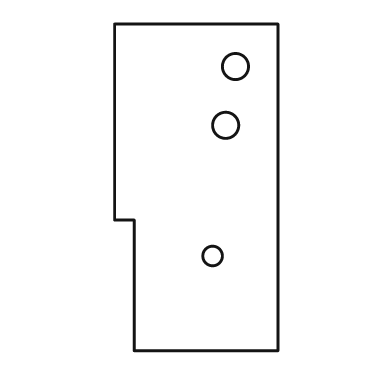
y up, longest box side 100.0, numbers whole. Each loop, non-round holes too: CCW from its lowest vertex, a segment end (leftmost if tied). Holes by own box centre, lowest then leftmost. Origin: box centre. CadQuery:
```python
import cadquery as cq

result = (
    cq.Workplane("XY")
    .moveTo(-19.0, -50.0)
    .lineTo(25.0, -50.0)
    .lineTo(25.0, 50.0)
    .lineTo(-25.0, 50.0)
    .lineTo(-25.0, -10.0)
    .lineTo(-19.0, -10.0)
    .close()
    .moveTo(5.0, -21.0)
    .circle(3.0)
    .moveTo(9.0, 19.0)
    .circle(4.0)
    .moveTo(12.0, 37.0)
    .circle(4.0)
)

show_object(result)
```